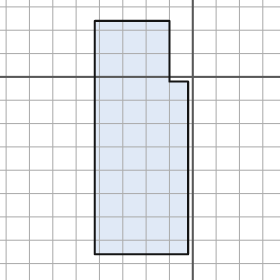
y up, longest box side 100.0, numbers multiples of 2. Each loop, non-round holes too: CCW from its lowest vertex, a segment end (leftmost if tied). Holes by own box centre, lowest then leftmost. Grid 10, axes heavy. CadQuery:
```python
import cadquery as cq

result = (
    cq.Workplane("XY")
    .moveTo(-42.0, -76.0)
    .lineTo(-2.0, -76.0)
    .lineTo(-2.0, -2.0)
    .lineTo(-10.0, -2.0)
    .lineTo(-10.0, 24.0)
    .lineTo(-42.0, 24.0)
    .close()
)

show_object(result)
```